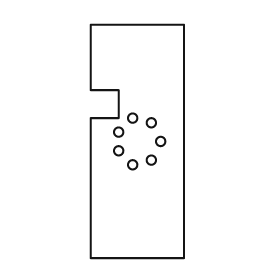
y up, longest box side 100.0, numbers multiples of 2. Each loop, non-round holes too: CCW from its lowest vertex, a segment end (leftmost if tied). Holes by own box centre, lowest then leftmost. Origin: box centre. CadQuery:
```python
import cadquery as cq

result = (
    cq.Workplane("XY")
    .moveTo(-20.0, -50.0)
    .lineTo(20.0, -50.0)
    .lineTo(20.0, 50.0)
    .lineTo(-20.0, 50.0)
    .lineTo(-20.0, 22.0)
    .lineTo(-8.0, 22.0)
    .lineTo(-8.0, 10.0)
    .lineTo(-20.0, 10.0)
    .close()
    .moveTo(-2.0, -10.0)
    .circle(2.0)
    .moveTo(6.0, -8.0)
    .circle(2.0)
    .moveTo(-8.0, -4.0)
    .circle(2.0)
    .moveTo(10.0, 0.0)
    .circle(2.0)
    .moveTo(-8.0, 4.0)
    .circle(2.0)
    .moveTo(6.0, 8.0)
    .circle(2.0)
    .moveTo(-2.0, 10.0)
    .circle(2.0)
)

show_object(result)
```